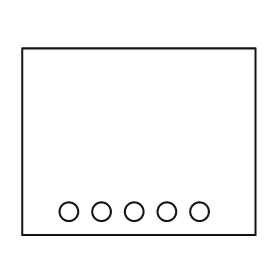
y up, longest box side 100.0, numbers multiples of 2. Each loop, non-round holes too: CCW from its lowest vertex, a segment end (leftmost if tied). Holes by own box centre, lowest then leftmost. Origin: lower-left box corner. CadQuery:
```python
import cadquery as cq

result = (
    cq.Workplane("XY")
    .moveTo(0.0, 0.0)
    .lineTo(100.0, 0.0)
    .lineTo(100.0, 80.0)
    .lineTo(0.0, 80.0)
    .close()
    .moveTo(20.0, 10.0)
    .circle(4.0)
    .moveTo(34.0, 10.0)
    .circle(4.0)
    .moveTo(48.0, 10.0)
    .circle(4.0)
    .moveTo(62.0, 10.0)
    .circle(4.0)
    .moveTo(76.0, 10.0)
    .circle(4.0)
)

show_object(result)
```